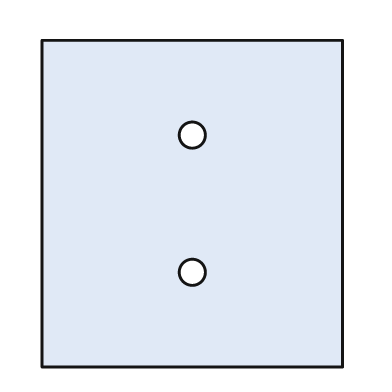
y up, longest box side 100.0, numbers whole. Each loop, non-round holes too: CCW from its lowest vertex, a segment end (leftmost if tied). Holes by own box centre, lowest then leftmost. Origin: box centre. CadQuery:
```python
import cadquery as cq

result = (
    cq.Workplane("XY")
    .moveTo(-46.0, -50.0)
    .lineTo(46.0, -50.0)
    .lineTo(46.0, 50.0)
    .lineTo(-46.0, 50.0)
    .close()
    .moveTo(0.0, -21.0)
    .circle(4.0)
    .moveTo(0.0, 21.0)
    .circle(4.0)
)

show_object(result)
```